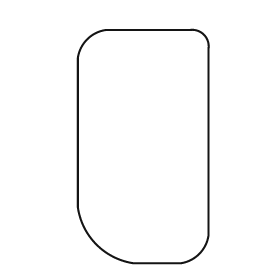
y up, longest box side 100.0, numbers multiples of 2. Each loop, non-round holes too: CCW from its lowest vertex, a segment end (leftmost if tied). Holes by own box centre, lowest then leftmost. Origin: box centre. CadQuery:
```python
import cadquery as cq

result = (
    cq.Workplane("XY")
    .moveTo(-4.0, -50.0)
    .lineTo(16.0, -50.0)
    .threePointArc((24.0, -46.0), (28.0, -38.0))
    .lineTo(28.0, 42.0)
    .threePointArc((26.0, 48.0), (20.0, 50.0))
    .lineTo(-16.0, 50.0)
    .threePointArc((-24.0, 46.0), (-28.0, 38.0))
    .lineTo(-28.0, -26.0)
    .threePointArc((-20.0, -42.0), (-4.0, -50.0))
    .close()
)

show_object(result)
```